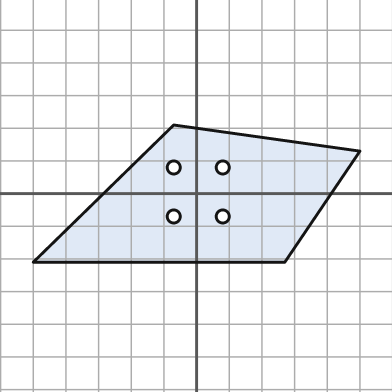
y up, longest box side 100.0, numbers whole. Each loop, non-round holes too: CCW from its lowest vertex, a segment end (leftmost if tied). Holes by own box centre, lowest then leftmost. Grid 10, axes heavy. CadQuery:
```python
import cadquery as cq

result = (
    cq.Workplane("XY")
    .moveTo(-50.0, -21.0)
    .lineTo(27.0, -21.0)
    .lineTo(50.0, 13.0)
    .lineTo(-7.0, 21.0)
    .close()
    .moveTo(-7.0, -7.0)
    .circle(2.0)
    .moveTo(8.0, -7.0)
    .circle(2.0)
    .moveTo(-7.0, 8.0)
    .circle(2.0)
    .moveTo(8.0, 8.0)
    .circle(2.0)
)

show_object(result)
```